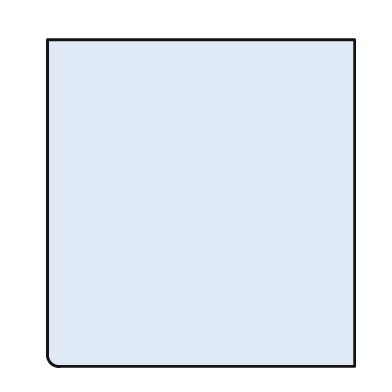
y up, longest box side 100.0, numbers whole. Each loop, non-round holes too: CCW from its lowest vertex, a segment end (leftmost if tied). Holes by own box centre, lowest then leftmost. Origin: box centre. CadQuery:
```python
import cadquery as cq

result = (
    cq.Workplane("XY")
    .moveTo(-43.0, -50.0)
    .lineTo(47.0, -50.0)
    .lineTo(47.0, 50.0)
    .lineTo(-47.0, 50.0)
    .lineTo(-47.0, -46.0)
    .threePointArc((-46.0, -49.0), (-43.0, -50.0))
    .close()
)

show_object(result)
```